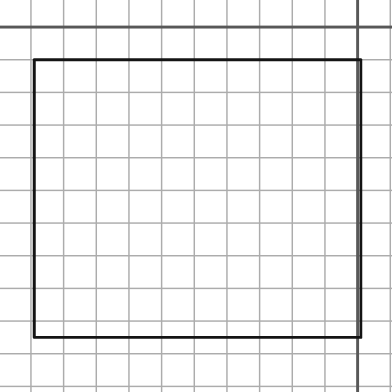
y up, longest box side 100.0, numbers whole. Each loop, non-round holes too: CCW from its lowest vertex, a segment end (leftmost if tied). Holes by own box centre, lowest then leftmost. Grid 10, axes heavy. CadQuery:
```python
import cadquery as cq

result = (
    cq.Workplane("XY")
    .moveTo(-99.0, -95.0)
    .lineTo(1.0, -95.0)
    .lineTo(1.0, -10.0)
    .lineTo(-99.0, -10.0)
    .close()
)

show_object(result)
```